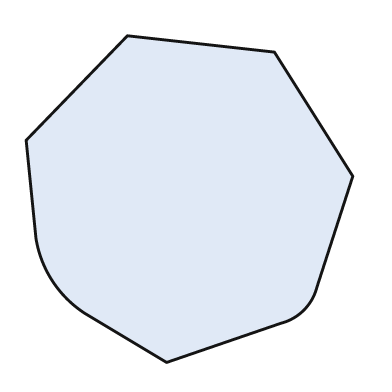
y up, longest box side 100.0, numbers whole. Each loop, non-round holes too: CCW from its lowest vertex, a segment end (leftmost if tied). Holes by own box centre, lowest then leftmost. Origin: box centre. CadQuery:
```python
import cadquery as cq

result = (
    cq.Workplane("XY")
    .moveTo(-7.0, -50.0)
    .lineTo(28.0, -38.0)
    .threePointArc((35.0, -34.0), (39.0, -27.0))
    .lineTo(50.0, 7.0)
    .lineTo(26.0, 45.0)
    .lineTo(-19.0, 50.0)
    .lineTo(-50.0, 18.0)
    .lineTo(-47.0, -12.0)
    .threePointArc((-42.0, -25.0), (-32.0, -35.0))
    .close()
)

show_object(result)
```